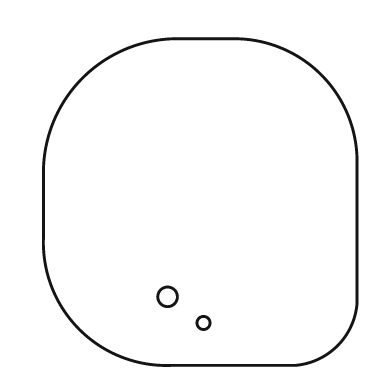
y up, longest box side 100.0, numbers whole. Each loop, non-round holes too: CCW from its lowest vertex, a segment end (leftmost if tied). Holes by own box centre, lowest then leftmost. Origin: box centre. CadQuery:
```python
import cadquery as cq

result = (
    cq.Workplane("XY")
    .moveTo(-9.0, -50.0)
    .lineTo(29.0, -50.0)
    .threePointArc((42.0, -44.0), (48.0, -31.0))
    .lineTo(48.0, 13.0)
    .threePointArc((37.0, 39.0), (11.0, 50.0))
    .lineTo(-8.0, 50.0)
    .threePointArc((-36.0, 38.0), (-48.0, 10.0))
    .lineTo(-48.0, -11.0)
    .threePointArc((-37.0, -39.0), (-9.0, -50.0))
    .close()
    .moveTo(1.0, -37.0)
    .circle(2.0)
    .moveTo(-10.0, -29.0)
    .circle(3.0)
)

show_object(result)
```